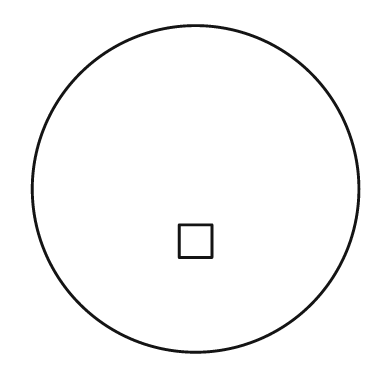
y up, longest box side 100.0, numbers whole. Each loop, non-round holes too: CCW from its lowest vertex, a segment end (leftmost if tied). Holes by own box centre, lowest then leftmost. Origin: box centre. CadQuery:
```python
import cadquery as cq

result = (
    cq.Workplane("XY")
    .moveTo(0.0, 0.0)
    .circle(50.0)
    .moveTo(-5.0, -21.0)
    .lineTo(5.0, -21.0)
    .lineTo(5.0, -11.0)
    .lineTo(-5.0, -11.0)
    .close()
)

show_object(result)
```